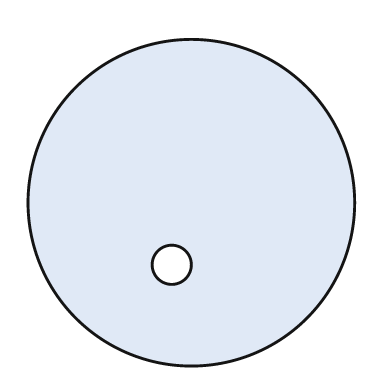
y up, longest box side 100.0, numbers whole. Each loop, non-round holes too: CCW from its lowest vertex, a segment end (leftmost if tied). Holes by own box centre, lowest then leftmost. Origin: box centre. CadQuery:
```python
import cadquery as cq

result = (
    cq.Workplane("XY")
    .moveTo(0.0, 0.0)
    .circle(50.0)
    .moveTo(-6.0, -19.0)
    .circle(6.0)
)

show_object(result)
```